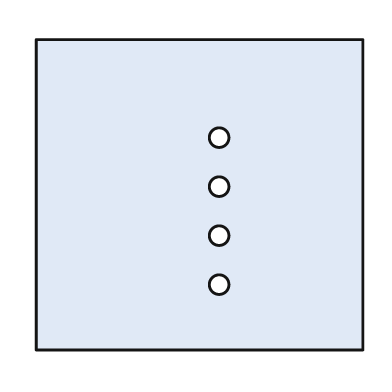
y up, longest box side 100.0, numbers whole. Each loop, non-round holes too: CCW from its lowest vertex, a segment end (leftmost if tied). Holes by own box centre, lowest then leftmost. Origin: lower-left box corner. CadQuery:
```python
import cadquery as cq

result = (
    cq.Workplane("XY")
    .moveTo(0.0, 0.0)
    .lineTo(100.0, 0.0)
    .lineTo(100.0, 95.0)
    .lineTo(0.0, 95.0)
    .close()
    .moveTo(56.0, 20.0)
    .circle(3.0)
    .moveTo(56.0, 35.0)
    .circle(3.0)
    .moveTo(56.0, 50.0)
    .circle(3.0)
    .moveTo(56.0, 65.0)
    .circle(3.0)
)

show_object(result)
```